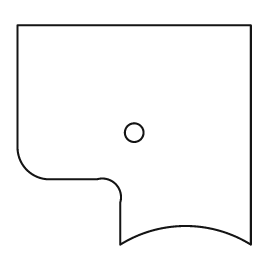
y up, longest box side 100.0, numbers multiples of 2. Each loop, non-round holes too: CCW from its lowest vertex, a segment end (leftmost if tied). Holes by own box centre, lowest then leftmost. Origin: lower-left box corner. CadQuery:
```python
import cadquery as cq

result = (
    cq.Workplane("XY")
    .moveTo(44.0, 0.0)
    .threePointArc((72.0, 8.0), (100.0, 0.0))
    .lineTo(100.0, 94.0)
    .lineTo(0.0, 94.0)
    .lineTo(0.0, 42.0)
    .threePointArc((4.0, 32.0), (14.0, 28.0))
    .lineTo(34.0, 28.0)
    .threePointArc((42.0, 26.0), (44.0, 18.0))
    .close()
    .moveTo(50.0, 48.0)
    .circle(4.0)
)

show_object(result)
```